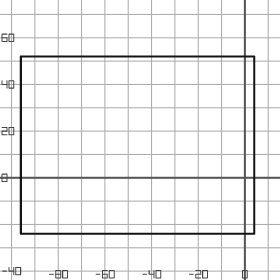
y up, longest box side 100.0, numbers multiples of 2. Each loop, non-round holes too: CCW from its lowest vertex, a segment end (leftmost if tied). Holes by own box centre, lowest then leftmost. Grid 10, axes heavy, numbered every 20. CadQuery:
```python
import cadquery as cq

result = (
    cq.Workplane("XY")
    .moveTo(-96.0, -24.0)
    .lineTo(4.0, -24.0)
    .lineTo(4.0, 52.0)
    .lineTo(-96.0, 52.0)
    .close()
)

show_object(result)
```